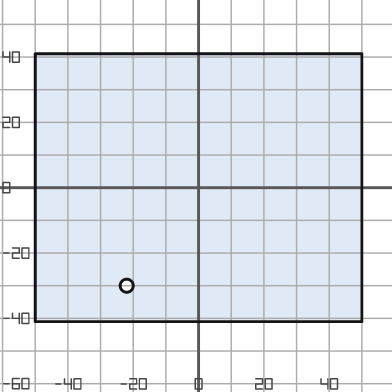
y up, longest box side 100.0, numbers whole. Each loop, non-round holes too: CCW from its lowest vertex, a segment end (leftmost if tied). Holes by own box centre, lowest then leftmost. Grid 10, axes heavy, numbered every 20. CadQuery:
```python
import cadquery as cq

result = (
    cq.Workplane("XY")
    .moveTo(-50.0, -41.0)
    .lineTo(50.0, -41.0)
    .lineTo(50.0, 41.0)
    .lineTo(-50.0, 41.0)
    .close()
    .moveTo(-22.0, -30.0)
    .circle(2.0)
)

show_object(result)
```